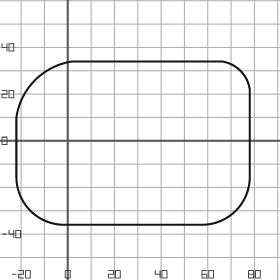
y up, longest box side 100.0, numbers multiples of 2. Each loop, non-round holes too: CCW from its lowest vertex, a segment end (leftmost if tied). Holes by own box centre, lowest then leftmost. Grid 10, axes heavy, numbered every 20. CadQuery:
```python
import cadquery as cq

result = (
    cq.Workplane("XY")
    .moveTo(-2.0, -36.0)
    .lineTo(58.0, -36.0)
    .threePointArc((72.0, -30.0), (78.0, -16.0))
    .lineTo(78.0, 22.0)
    .threePointArc((74.0, 30.0), (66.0, 34.0))
    .lineTo(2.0, 34.0)
    .threePointArc((-14.0, 26.0), (-22.0, 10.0))
    .lineTo(-22.0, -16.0)
    .threePointArc((-16.0, -30.0), (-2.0, -36.0))
    .close()
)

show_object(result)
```